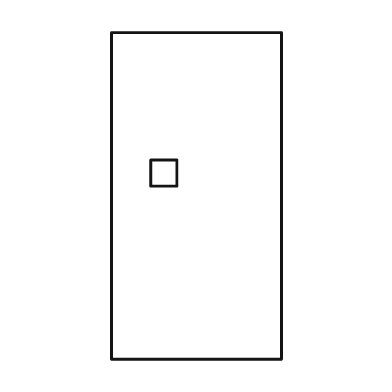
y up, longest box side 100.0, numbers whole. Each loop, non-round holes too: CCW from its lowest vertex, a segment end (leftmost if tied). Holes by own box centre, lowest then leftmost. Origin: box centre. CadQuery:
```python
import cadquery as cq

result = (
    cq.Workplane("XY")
    .moveTo(-26.0, -50.0)
    .lineTo(26.0, -50.0)
    .lineTo(26.0, 50.0)
    .lineTo(-26.0, 50.0)
    .close()
    .moveTo(-14.0, 3.0)
    .lineTo(-6.0, 3.0)
    .lineTo(-6.0, 11.0)
    .lineTo(-14.0, 11.0)
    .close()
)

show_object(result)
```